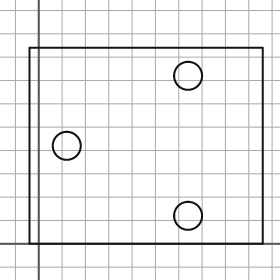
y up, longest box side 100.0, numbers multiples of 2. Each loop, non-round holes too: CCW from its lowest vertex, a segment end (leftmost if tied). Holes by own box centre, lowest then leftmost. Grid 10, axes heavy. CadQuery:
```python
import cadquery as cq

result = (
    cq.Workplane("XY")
    .moveTo(-4.0, 0.0)
    .lineTo(96.0, 0.0)
    .lineTo(96.0, 84.0)
    .lineTo(-4.0, 84.0)
    .close()
    .moveTo(64.0, 12.0)
    .circle(6.0)
    .moveTo(12.0, 42.0)
    .circle(6.0)
    .moveTo(64.0, 72.0)
    .circle(6.0)
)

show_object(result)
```